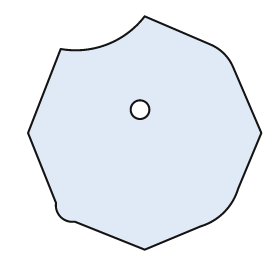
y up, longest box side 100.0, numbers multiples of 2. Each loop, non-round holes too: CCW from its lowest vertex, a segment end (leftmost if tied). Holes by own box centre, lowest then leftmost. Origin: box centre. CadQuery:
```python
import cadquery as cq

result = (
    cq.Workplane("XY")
    .moveTo(0.0, -50.0)
    .lineTo(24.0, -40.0)
    .threePointArc((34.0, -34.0), (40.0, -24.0))
    .lineTo(50.0, 0.0)
    .lineTo(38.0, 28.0)
    .threePointArc((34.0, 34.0), (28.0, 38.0))
    .lineTo(0.0, 50.0)
    .threePointArc((-16.0, 38.0), (-36.0, 36.0))
    .lineTo(-50.0, 0.0)
    .lineTo(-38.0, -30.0)
    .threePointArc((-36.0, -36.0), (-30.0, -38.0))
    .close()
    .moveTo(-2.0, 10.0)
    .circle(4.0)
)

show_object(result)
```